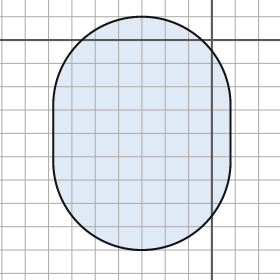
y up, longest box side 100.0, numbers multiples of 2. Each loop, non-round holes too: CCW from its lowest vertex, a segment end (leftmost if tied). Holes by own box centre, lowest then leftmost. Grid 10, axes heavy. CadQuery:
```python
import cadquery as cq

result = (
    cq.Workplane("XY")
    .moveTo(-68.0, -52.0)
    .threePointArc((-30.0, -90.0), (8.0, -52.0))
    .lineTo(8.0, -28.0)
    .threePointArc((-30.0, 10.0), (-68.0, -28.0))
    .close()
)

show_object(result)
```